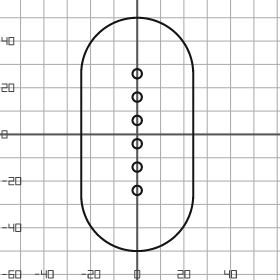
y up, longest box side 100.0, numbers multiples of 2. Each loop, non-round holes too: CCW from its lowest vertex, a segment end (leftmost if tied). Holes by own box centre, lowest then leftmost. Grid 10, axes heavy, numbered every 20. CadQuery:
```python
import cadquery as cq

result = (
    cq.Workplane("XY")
    .moveTo(-24.0, -26.0)
    .threePointArc((0.0, -50.0), (24.0, -26.0))
    .lineTo(24.0, 26.0)
    .threePointArc((0.0, 50.0), (-24.0, 26.0))
    .close()
    .moveTo(0.0, -24.0)
    .circle(2.0)
    .moveTo(0.0, -14.0)
    .circle(2.0)
    .moveTo(0.0, -4.0)
    .circle(2.0)
    .moveTo(0.0, 6.0)
    .circle(2.0)
    .moveTo(0.0, 16.0)
    .circle(2.0)
    .moveTo(0.0, 26.0)
    .circle(2.0)
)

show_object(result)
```